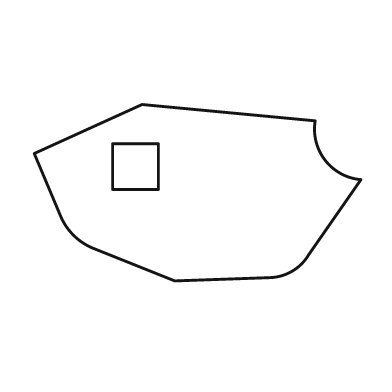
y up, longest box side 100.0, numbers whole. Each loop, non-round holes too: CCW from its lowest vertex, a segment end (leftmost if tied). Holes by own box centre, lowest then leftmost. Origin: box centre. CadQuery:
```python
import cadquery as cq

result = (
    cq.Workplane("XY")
    .moveTo(-7.0, -27.0)
    .lineTo(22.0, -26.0)
    .threePointArc((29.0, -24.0), (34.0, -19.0))
    .lineTo(50.0, 4.0)
    .threePointArc((39.0, 10.0), (36.0, 22.0))
    .lineTo(-17.0, 27.0)
    .lineTo(-50.0, 12.0)
    .lineTo(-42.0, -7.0)
    .threePointArc((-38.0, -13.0), (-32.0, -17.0))
    .close()
    .moveTo(-26.0, 1.0)
    .lineTo(-12.0, 1.0)
    .lineTo(-12.0, 15.0)
    .lineTo(-26.0, 15.0)
    .close()
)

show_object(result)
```